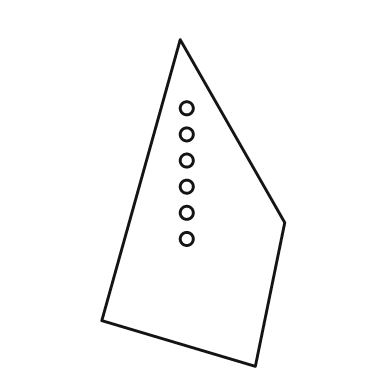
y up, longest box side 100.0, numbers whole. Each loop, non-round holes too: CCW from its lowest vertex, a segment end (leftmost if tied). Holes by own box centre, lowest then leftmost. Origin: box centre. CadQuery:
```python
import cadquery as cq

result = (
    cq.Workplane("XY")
    .moveTo(19.0, -50.0)
    .lineTo(28.0, -6.0)
    .lineTo(-4.0, 50.0)
    .lineTo(-28.0, -36.0)
    .close()
    .moveTo(-2.0, -11.0)
    .circle(2.0)
    .moveTo(-2.0, -3.0)
    .circle(2.0)
    .moveTo(-2.0, 5.0)
    .circle(2.0)
    .moveTo(-2.0, 13.0)
    .circle(2.0)
    .moveTo(-2.0, 21.0)
    .circle(2.0)
    .moveTo(-2.0, 29.0)
    .circle(2.0)
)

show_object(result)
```